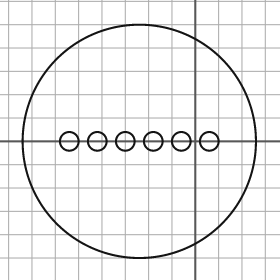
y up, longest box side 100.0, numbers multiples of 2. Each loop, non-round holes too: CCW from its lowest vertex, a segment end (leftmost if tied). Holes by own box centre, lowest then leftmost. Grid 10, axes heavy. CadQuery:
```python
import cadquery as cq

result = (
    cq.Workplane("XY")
    .moveTo(-24.0, 0.0)
    .circle(50.0)
    .moveTo(-54.0, 0.0)
    .circle(4.0)
    .moveTo(-42.0, 0.0)
    .circle(4.0)
    .moveTo(-30.0, 0.0)
    .circle(4.0)
    .moveTo(-18.0, 0.0)
    .circle(4.0)
    .moveTo(-6.0, 0.0)
    .circle(4.0)
    .moveTo(6.0, 0.0)
    .circle(4.0)
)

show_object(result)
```